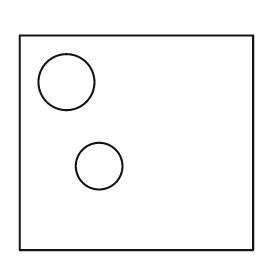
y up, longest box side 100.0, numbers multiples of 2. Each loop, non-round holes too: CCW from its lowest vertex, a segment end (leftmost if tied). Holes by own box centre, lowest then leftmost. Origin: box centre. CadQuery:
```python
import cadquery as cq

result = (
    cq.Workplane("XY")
    .moveTo(-50.0, -46.0)
    .lineTo(50.0, -46.0)
    .lineTo(50.0, 46.0)
    .lineTo(-50.0, 46.0)
    .close()
    .moveTo(-16.0, -10.0)
    .circle(10.0)
    .moveTo(-30.0, 26.0)
    .circle(12.0)
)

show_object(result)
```